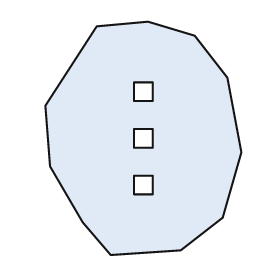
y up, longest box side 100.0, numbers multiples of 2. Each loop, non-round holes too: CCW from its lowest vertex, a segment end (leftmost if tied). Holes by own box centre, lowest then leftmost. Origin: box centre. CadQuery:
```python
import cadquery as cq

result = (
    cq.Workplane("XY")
    .moveTo(-14.0, -50.0)
    .lineTo(16.0, -48.0)
    .lineTo(34.0, -34.0)
    .lineTo(42.0, -6.0)
    .lineTo(36.0, 26.0)
    .lineTo(22.0, 44.0)
    .lineTo(2.0, 50.0)
    .lineTo(-20.0, 48.0)
    .lineTo(-42.0, 14.0)
    .lineTo(-40.0, -12.0)
    .lineTo(-26.0, -36.0)
    .close()
    .moveTo(-4.0, -24.0)
    .lineTo(4.0, -24.0)
    .lineTo(4.0, -16.0)
    .lineTo(-4.0, -16.0)
    .close()
    .moveTo(-4.0, -4.0)
    .lineTo(4.0, -4.0)
    .lineTo(4.0, 4.0)
    .lineTo(-4.0, 4.0)
    .close()
    .moveTo(-4.0, 16.0)
    .lineTo(4.0, 16.0)
    .lineTo(4.0, 24.0)
    .lineTo(-4.0, 24.0)
    .close()
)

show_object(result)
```